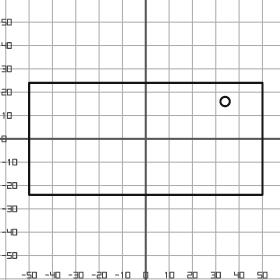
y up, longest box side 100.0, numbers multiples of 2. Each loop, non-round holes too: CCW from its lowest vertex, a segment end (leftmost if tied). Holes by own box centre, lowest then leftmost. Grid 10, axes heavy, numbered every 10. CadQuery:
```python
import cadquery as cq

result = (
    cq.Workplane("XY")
    .moveTo(-50.0, -24.0)
    .lineTo(50.0, -24.0)
    .lineTo(50.0, 24.0)
    .lineTo(-50.0, 24.0)
    .close()
    .moveTo(34.0, 16.0)
    .circle(2.0)
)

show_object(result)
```